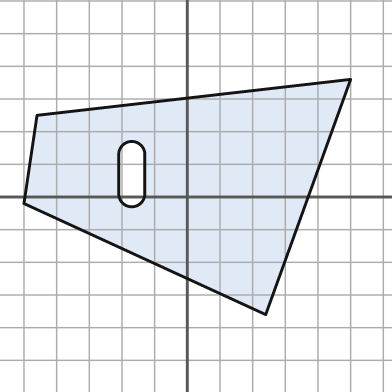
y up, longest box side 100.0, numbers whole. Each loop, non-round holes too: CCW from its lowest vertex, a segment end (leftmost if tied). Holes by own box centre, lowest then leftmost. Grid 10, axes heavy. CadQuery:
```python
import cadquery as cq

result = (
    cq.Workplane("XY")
    .moveTo(24.0, -36.0)
    .lineTo(50.0, 36.0)
    .lineTo(-46.0, 25.0)
    .lineTo(-50.0, -2.0)
    .close()
    .moveTo(-21.0, 1.0)
    .threePointArc((-17.0, -3.0), (-13.0, 1.0))
    .lineTo(-13.0, 13.0)
    .threePointArc((-17.0, 17.0), (-21.0, 13.0))
    .close()
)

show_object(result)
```